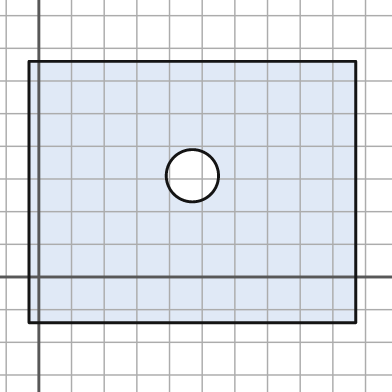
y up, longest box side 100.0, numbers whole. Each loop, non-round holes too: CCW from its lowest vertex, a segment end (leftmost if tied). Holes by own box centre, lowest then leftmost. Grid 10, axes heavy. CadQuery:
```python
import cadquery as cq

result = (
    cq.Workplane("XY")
    .moveTo(-3.0, -14.0)
    .lineTo(97.0, -14.0)
    .lineTo(97.0, 66.0)
    .lineTo(-3.0, 66.0)
    .close()
    .moveTo(47.0, 31.0)
    .circle(8.0)
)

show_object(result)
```